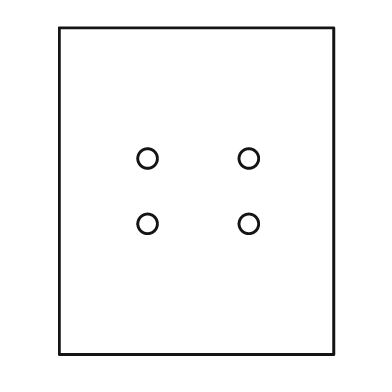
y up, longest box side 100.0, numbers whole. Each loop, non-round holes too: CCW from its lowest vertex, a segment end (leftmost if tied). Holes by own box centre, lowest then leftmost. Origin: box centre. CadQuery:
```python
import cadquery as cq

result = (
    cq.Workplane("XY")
    .moveTo(-42.0, -50.0)
    .lineTo(42.0, -50.0)
    .lineTo(42.0, 50.0)
    .lineTo(-42.0, 50.0)
    .close()
    .moveTo(-15.0, -10.0)
    .circle(3.0)
    .moveTo(16.0, -10.0)
    .circle(3.0)
    .moveTo(-15.0, 10.0)
    .circle(3.0)
    .moveTo(16.0, 10.0)
    .circle(3.0)
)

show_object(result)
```